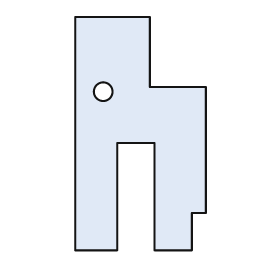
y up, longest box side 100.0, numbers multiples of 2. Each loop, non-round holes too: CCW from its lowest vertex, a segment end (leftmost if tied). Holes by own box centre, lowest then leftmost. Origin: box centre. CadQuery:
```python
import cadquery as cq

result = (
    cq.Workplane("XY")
    .moveTo(-28.0, -50.0)
    .lineTo(-10.0, -50.0)
    .lineTo(-10.0, -4.0)
    .lineTo(6.0, -4.0)
    .lineTo(6.0, -50.0)
    .lineTo(22.0, -50.0)
    .lineTo(22.0, -34.0)
    .lineTo(28.0, -34.0)
    .lineTo(28.0, 20.0)
    .lineTo(4.0, 20.0)
    .lineTo(4.0, 50.0)
    .lineTo(-28.0, 50.0)
    .close()
    .moveTo(-16.0, 18.0)
    .circle(4.0)
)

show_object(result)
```